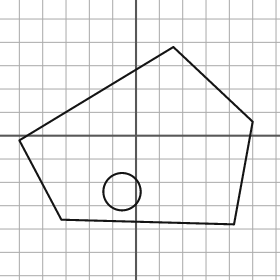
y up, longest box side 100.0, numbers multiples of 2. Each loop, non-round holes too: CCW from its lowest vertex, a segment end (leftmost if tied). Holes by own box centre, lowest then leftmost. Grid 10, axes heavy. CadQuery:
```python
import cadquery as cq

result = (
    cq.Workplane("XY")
    .moveTo(42.0, -38.0)
    .lineTo(50.0, 6.0)
    .lineTo(16.0, 38.0)
    .lineTo(-50.0, -2.0)
    .lineTo(-32.0, -36.0)
    .close()
    .moveTo(-6.0, -24.0)
    .circle(8.0)
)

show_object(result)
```